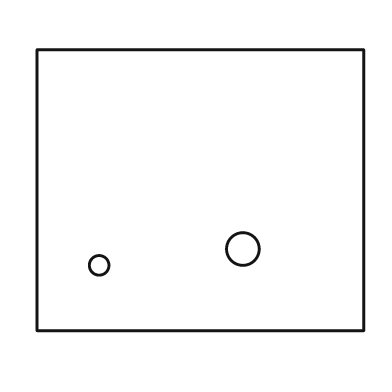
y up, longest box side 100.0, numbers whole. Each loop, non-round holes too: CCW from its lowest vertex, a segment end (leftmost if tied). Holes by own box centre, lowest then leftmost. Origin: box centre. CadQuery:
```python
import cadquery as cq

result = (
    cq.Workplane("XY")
    .moveTo(-50.0, -43.0)
    .lineTo(50.0, -43.0)
    .lineTo(50.0, 43.0)
    .lineTo(-50.0, 43.0)
    .close()
    .moveTo(-31.0, -23.0)
    .circle(3.0)
    .moveTo(13.0, -18.0)
    .circle(5.0)
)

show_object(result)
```